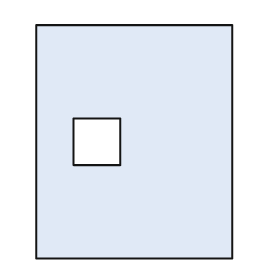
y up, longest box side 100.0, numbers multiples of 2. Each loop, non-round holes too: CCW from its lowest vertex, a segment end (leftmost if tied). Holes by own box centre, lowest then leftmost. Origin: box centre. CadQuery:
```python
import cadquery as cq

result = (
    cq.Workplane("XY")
    .moveTo(-42.0, -50.0)
    .lineTo(42.0, -50.0)
    .lineTo(42.0, 50.0)
    .lineTo(-42.0, 50.0)
    .close()
    .moveTo(-26.0, -10.0)
    .lineTo(-6.0, -10.0)
    .lineTo(-6.0, 10.0)
    .lineTo(-26.0, 10.0)
    .close()
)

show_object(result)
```